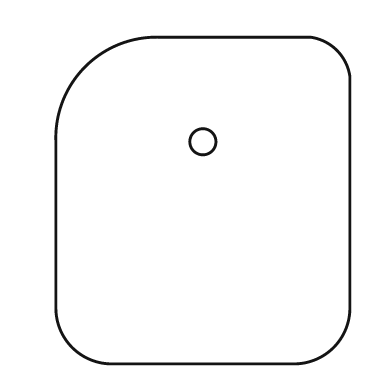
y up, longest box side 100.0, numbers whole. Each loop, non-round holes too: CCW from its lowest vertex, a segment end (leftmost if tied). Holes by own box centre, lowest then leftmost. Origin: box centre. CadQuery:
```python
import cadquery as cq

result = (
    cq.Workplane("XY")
    .moveTo(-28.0, -50.0)
    .lineTo(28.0, -50.0)
    .threePointArc((40.0, -45.0), (45.0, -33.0))
    .lineTo(45.0, 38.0)
    .threePointArc((41.0, 46.0), (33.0, 50.0))
    .lineTo(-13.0, 50.0)
    .threePointArc((-36.0, 41.0), (-45.0, 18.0))
    .lineTo(-45.0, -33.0)
    .threePointArc((-40.0, -45.0), (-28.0, -50.0))
    .close()
    .moveTo(0.0, 18.0)
    .circle(4.0)
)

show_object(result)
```